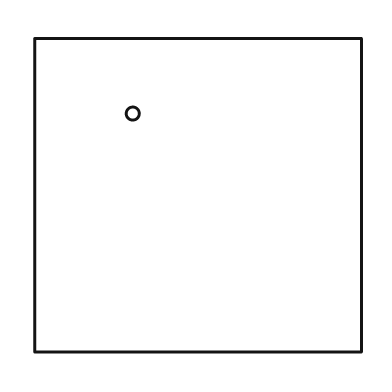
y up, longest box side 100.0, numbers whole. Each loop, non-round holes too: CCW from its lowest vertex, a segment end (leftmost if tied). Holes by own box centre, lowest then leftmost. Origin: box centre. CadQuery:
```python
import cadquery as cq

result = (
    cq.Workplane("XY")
    .moveTo(-50.0, -48.0)
    .lineTo(50.0, -48.0)
    .lineTo(50.0, 48.0)
    .lineTo(-50.0, 48.0)
    .close()
    .moveTo(-20.0, 25.0)
    .circle(2.0)
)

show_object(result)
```